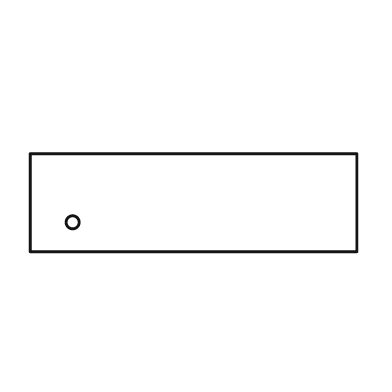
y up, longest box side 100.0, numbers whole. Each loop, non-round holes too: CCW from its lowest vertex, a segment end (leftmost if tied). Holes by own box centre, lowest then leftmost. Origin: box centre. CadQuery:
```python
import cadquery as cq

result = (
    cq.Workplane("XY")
    .moveTo(-50.0, -15.0)
    .lineTo(50.0, -15.0)
    .lineTo(50.0, 15.0)
    .lineTo(-50.0, 15.0)
    .close()
    .moveTo(-37.0, -6.0)
    .circle(2.0)
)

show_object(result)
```